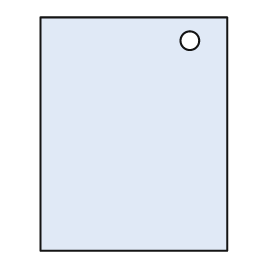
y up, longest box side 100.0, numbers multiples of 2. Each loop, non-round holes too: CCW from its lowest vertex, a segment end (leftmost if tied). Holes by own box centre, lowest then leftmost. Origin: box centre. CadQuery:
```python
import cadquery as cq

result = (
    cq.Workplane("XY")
    .moveTo(-40.0, -50.0)
    .lineTo(40.0, -50.0)
    .lineTo(40.0, 50.0)
    .lineTo(-40.0, 50.0)
    .close()
    .moveTo(24.0, 40.0)
    .circle(4.0)
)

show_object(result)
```